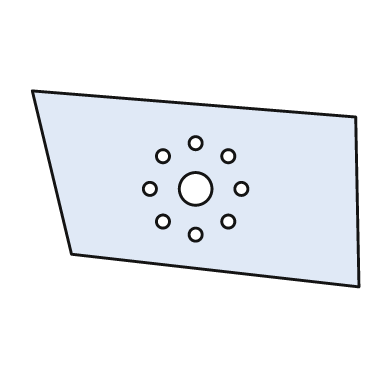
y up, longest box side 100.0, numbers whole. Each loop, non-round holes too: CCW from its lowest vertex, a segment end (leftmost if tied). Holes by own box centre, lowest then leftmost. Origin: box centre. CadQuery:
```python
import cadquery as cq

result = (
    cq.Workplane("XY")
    .moveTo(50.0, -30.0)
    .lineTo(49.0, 22.0)
    .lineTo(-50.0, 30.0)
    .lineTo(-38.0, -20.0)
    .close()
    .moveTo(0.0, -14.0)
    .circle(2.0)
    .moveTo(-10.0, -10.0)
    .circle(2.0)
    .moveTo(10.0, -10.0)
    .circle(2.0)
    .moveTo(-14.0, 0.0)
    .circle(2.0)
    .moveTo(0.0, 0.0)
    .circle(5.0)
    .moveTo(14.0, 0.0)
    .circle(2.0)
    .moveTo(-10.0, 10.0)
    .circle(2.0)
    .moveTo(10.0, 10.0)
    .circle(2.0)
    .moveTo(0.0, 14.0)
    .circle(2.0)
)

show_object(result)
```